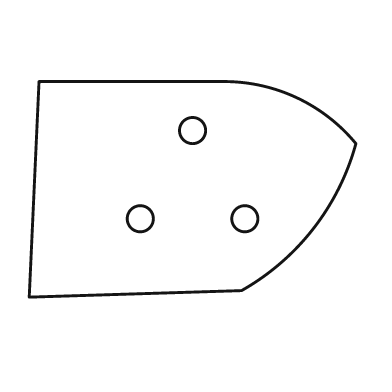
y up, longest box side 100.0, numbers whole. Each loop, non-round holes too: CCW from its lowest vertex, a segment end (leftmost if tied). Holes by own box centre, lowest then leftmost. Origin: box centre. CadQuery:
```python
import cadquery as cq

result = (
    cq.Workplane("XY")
    .moveTo(-50.0, -33.0)
    .lineTo(15.0, -31.0)
    .threePointArc((37.0, -12.0), (50.0, 14.0))
    .threePointArc((32.0, 28.0), (10.0, 33.0))
    .lineTo(-47.0, 33.0)
    .close()
    .moveTo(-16.0, -9.0)
    .circle(4.0)
    .moveTo(16.0, -9.0)
    .circle(4.0)
    .moveTo(0.0, 18.0)
    .circle(4.0)
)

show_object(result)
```